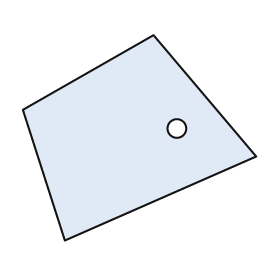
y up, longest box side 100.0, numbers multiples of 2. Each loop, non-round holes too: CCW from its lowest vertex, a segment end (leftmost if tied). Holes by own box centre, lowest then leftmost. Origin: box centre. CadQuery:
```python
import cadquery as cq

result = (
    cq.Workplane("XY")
    .moveTo(-32.0, -44.0)
    .lineTo(50.0, -8.0)
    .lineTo(6.0, 44.0)
    .lineTo(-50.0, 12.0)
    .close()
    .moveTo(16.0, 4.0)
    .circle(4.0)
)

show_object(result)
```